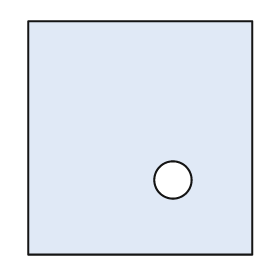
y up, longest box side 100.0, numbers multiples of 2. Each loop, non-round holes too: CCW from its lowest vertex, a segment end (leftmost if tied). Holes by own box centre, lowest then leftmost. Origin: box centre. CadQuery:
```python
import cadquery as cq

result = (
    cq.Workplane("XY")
    .moveTo(-48.0, -50.0)
    .lineTo(48.0, -50.0)
    .lineTo(48.0, 50.0)
    .lineTo(-48.0, 50.0)
    .close()
    .moveTo(14.0, -18.0)
    .circle(8.0)
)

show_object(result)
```